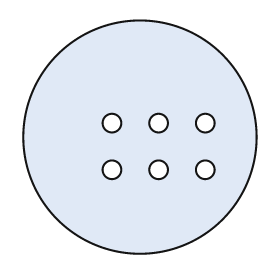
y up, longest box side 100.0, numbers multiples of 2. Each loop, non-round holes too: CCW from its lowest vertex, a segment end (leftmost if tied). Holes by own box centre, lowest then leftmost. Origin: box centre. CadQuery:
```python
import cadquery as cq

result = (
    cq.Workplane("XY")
    .moveTo(0.0, 0.0)
    .circle(50.0)
    .moveTo(-12.0, -14.0)
    .circle(4.0)
    .moveTo(8.0, -14.0)
    .circle(4.0)
    .moveTo(28.0, -14.0)
    .circle(4.0)
    .moveTo(-12.0, 6.0)
    .circle(4.0)
    .moveTo(8.0, 6.0)
    .circle(4.0)
    .moveTo(28.0, 6.0)
    .circle(4.0)
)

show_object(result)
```